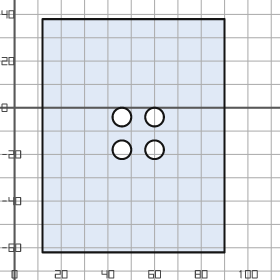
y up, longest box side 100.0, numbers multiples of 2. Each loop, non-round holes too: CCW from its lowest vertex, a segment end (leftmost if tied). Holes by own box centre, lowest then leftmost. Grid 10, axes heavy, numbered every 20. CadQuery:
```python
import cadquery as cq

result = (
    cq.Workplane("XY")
    .moveTo(12.0, -62.0)
    .lineTo(90.0, -62.0)
    .lineTo(90.0, 38.0)
    .lineTo(12.0, 38.0)
    .close()
    .moveTo(46.0, -18.0)
    .circle(4.0)
    .moveTo(60.0, -18.0)
    .circle(4.0)
    .moveTo(46.0, -4.0)
    .circle(4.0)
    .moveTo(60.0, -4.0)
    .circle(4.0)
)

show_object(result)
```